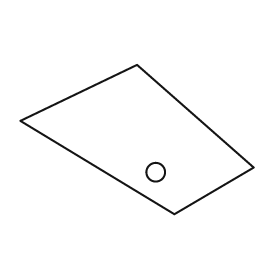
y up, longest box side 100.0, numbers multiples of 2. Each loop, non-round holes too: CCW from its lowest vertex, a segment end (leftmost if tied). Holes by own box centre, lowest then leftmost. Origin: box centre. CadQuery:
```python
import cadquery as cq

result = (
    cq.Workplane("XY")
    .moveTo(16.0, -32.0)
    .lineTo(50.0, -12.0)
    .lineTo(0.0, 32.0)
    .lineTo(-50.0, 8.0)
    .close()
    .moveTo(8.0, -14.0)
    .circle(4.0)
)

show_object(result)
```